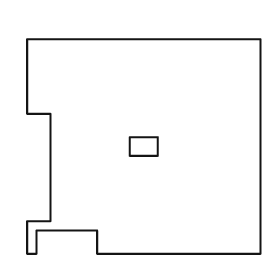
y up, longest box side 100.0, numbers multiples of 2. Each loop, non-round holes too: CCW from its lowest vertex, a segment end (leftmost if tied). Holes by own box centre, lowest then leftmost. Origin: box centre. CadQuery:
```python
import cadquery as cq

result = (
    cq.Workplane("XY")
    .moveTo(-50.0, -46.0)
    .lineTo(-46.0, -46.0)
    .lineTo(-46.0, -36.0)
    .lineTo(-20.0, -36.0)
    .lineTo(-20.0, -46.0)
    .lineTo(50.0, -46.0)
    .lineTo(50.0, 46.0)
    .lineTo(-50.0, 46.0)
    .lineTo(-50.0, 14.0)
    .lineTo(-40.0, 14.0)
    .lineTo(-40.0, -32.0)
    .lineTo(-50.0, -32.0)
    .close()
    .moveTo(-6.0, -4.0)
    .lineTo(6.0, -4.0)
    .lineTo(6.0, 4.0)
    .lineTo(-6.0, 4.0)
    .close()
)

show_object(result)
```